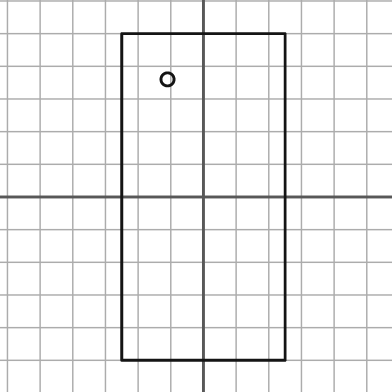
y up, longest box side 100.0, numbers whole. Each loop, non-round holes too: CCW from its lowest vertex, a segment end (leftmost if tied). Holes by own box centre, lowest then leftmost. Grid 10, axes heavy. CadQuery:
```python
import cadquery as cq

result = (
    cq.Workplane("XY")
    .moveTo(-25.0, -50.0)
    .lineTo(25.0, -50.0)
    .lineTo(25.0, 50.0)
    .lineTo(-25.0, 50.0)
    .close()
    .moveTo(-11.0, 36.0)
    .circle(2.0)
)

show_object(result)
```